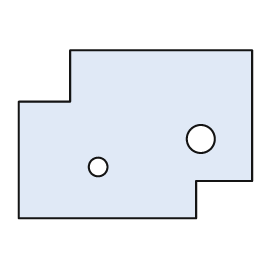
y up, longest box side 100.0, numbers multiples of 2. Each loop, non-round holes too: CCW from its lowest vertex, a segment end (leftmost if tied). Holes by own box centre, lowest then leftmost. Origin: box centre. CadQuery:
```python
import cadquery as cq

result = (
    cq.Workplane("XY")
    .moveTo(-50.0, -36.0)
    .lineTo(26.0, -36.0)
    .lineTo(26.0, -20.0)
    .lineTo(50.0, -20.0)
    .lineTo(50.0, 36.0)
    .lineTo(-28.0, 36.0)
    .lineTo(-28.0, 14.0)
    .lineTo(-50.0, 14.0)
    .close()
    .moveTo(-16.0, -14.0)
    .circle(4.0)
    .moveTo(28.0, -2.0)
    .circle(6.0)
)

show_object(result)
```